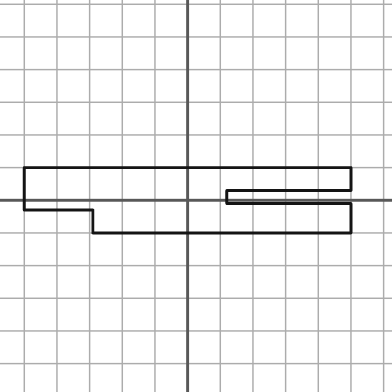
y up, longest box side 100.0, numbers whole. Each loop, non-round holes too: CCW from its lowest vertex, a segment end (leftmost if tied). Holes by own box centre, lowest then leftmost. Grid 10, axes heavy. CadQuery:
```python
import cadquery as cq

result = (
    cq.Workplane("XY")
    .moveTo(-29.0, -10.0)
    .lineTo(50.0, -10.0)
    .lineTo(50.0, -1.0)
    .lineTo(12.0, -1.0)
    .lineTo(12.0, 3.0)
    .lineTo(50.0, 3.0)
    .lineTo(50.0, 10.0)
    .lineTo(-50.0, 10.0)
    .lineTo(-50.0, -3.0)
    .lineTo(-29.0, -3.0)
    .close()
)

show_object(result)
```